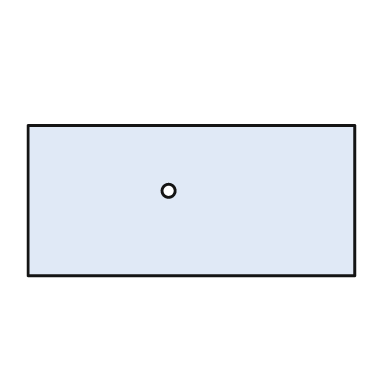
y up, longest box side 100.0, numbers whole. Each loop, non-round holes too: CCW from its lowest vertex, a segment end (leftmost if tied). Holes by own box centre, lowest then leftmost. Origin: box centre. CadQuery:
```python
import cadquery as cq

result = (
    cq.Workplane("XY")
    .moveTo(-50.0, -23.0)
    .lineTo(50.0, -23.0)
    .lineTo(50.0, 23.0)
    .lineTo(-50.0, 23.0)
    .close()
    .moveTo(-7.0, 3.0)
    .circle(2.0)
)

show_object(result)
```